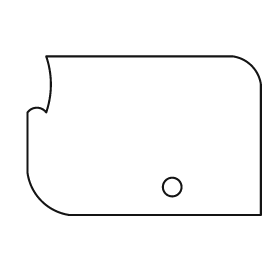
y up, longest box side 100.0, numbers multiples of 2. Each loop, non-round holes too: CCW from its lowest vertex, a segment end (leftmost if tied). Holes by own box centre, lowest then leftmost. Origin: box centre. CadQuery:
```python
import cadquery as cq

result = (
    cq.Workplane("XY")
    .moveTo(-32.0, -34.0)
    .lineTo(50.0, -34.0)
    .lineTo(50.0, 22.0)
    .threePointArc((46.0, 30.0), (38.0, 34.0))
    .lineTo(-42.0, 34.0)
    .threePointArc((-40.0, 22.0), (-42.0, 10.0))
    .threePointArc((-46.0, 12.0), (-50.0, 10.0))
    .lineTo(-50.0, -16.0)
    .threePointArc((-44.0, -28.0), (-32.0, -34.0))
    .close()
    .moveTo(12.0, -22.0)
    .circle(4.0)
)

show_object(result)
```